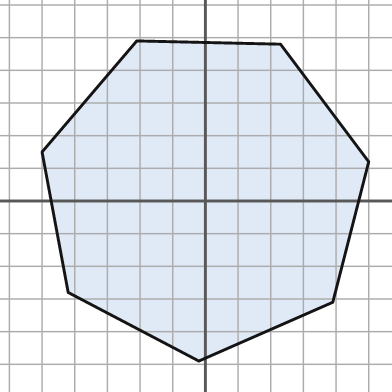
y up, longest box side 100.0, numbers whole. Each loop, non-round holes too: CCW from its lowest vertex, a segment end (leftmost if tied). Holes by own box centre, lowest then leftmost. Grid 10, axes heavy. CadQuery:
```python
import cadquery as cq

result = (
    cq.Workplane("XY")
    .moveTo(-2.0, -49.0)
    .lineTo(39.0, -31.0)
    .lineTo(50.0, 12.0)
    .lineTo(23.0, 48.0)
    .lineTo(-21.0, 49.0)
    .lineTo(-50.0, 15.0)
    .lineTo(-42.0, -28.0)
    .close()
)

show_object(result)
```